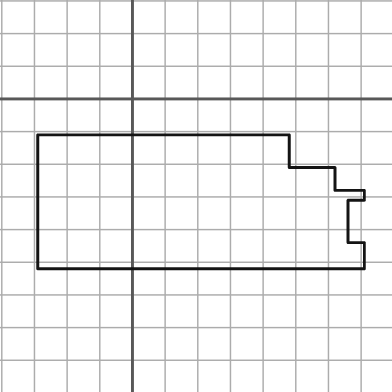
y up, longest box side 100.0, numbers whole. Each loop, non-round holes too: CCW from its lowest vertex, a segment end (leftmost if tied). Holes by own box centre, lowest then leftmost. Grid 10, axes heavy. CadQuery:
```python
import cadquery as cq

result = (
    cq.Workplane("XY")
    .moveTo(-29.0, -52.0)
    .lineTo(71.0, -52.0)
    .lineTo(71.0, -44.0)
    .lineTo(66.0, -44.0)
    .lineTo(66.0, -31.0)
    .lineTo(71.0, -31.0)
    .lineTo(71.0, -28.0)
    .lineTo(62.0, -28.0)
    .lineTo(62.0, -21.0)
    .lineTo(48.0, -21.0)
    .lineTo(48.0, -11.0)
    .lineTo(-29.0, -11.0)
    .close()
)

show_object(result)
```